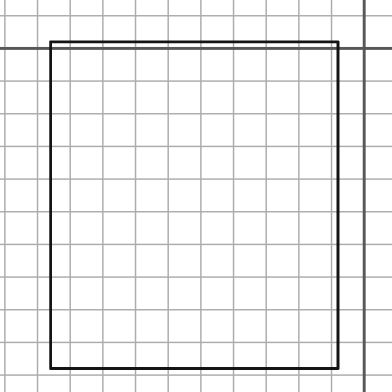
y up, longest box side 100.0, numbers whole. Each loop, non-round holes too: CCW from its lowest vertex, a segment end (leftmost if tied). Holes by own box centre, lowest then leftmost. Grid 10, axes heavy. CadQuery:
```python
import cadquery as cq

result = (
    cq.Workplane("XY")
    .moveTo(-96.0, -98.0)
    .lineTo(-8.0, -98.0)
    .lineTo(-8.0, 2.0)
    .lineTo(-96.0, 2.0)
    .close()
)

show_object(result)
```